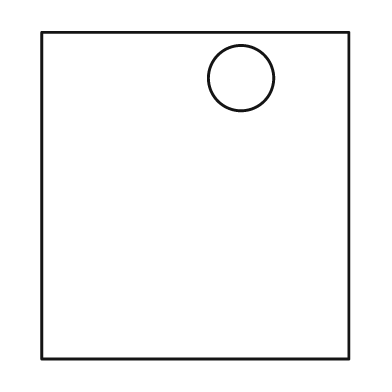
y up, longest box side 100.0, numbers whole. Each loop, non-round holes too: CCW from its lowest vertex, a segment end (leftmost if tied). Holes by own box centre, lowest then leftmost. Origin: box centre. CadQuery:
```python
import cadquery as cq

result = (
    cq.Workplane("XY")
    .moveTo(-47.0, -50.0)
    .lineTo(47.0, -50.0)
    .lineTo(47.0, 50.0)
    .lineTo(-47.0, 50.0)
    .close()
    .moveTo(14.0, 36.0)
    .circle(10.0)
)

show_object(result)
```